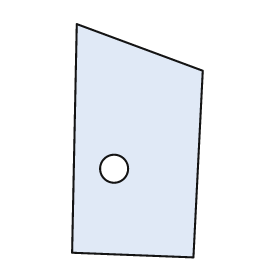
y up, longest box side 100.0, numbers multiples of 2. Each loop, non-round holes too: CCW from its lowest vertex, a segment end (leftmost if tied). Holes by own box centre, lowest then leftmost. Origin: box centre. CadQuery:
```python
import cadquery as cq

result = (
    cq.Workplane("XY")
    .moveTo(24.0, -50.0)
    .lineTo(28.0, 30.0)
    .lineTo(-26.0, 50.0)
    .lineTo(-28.0, -48.0)
    .close()
    .moveTo(-10.0, -12.0)
    .circle(6.0)
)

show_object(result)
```